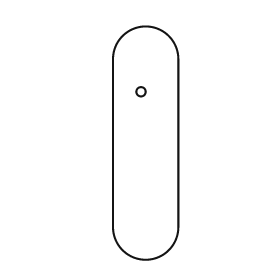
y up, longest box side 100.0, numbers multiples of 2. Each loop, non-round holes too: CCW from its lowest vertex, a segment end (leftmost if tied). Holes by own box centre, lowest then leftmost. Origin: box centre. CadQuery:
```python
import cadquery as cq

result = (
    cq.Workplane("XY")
    .moveTo(-14.0, -36.0)
    .threePointArc((0.0, -50.0), (14.0, -36.0))
    .lineTo(14.0, 36.0)
    .threePointArc((0.0, 50.0), (-14.0, 36.0))
    .close()
    .moveTo(-2.0, 22.0)
    .circle(2.0)
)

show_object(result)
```